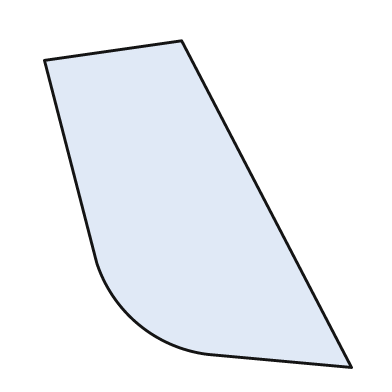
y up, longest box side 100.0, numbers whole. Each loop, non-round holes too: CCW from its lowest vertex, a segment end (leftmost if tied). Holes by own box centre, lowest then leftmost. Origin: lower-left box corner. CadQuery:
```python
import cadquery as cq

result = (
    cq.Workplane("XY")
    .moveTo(94.0, 0.0)
    .lineTo(42.0, 100.0)
    .lineTo(0.0, 94.0)
    .lineTo(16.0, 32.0)
    .threePointArc((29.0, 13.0), (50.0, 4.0))
    .close()
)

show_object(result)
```